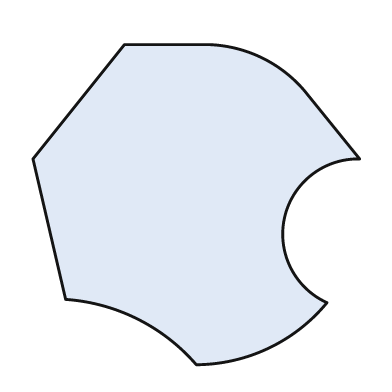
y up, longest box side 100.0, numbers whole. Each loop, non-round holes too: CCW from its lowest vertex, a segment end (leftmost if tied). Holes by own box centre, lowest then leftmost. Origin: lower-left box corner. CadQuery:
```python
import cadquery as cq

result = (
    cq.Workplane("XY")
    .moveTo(50.0, 0.0)
    .threePointArc((72.0, 5.0), (90.0, 19.0))
    .threePointArc((77.0, 45.0), (100.0, 63.0))
    .lineTo(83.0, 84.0)
    .threePointArc((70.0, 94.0), (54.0, 98.0))
    .lineTo(28.0, 98.0)
    .lineTo(0.0, 63.0)
    .lineTo(10.0, 20.0)
    .threePointArc((32.0, 14.0), (50.0, 0.0))
    .close()
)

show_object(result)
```